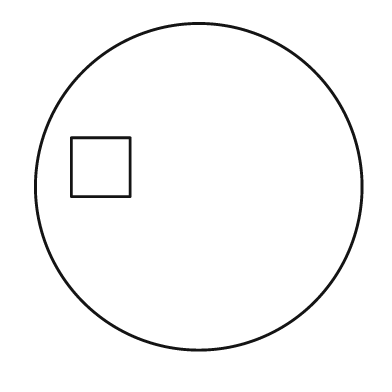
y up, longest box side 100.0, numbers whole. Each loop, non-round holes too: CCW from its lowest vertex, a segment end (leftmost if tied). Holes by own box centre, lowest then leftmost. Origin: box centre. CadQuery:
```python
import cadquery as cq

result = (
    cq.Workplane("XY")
    .moveTo(0.0, 0.0)
    .circle(50.0)
    .moveTo(-39.0, -3.0)
    .lineTo(-21.0, -3.0)
    .lineTo(-21.0, 15.0)
    .lineTo(-39.0, 15.0)
    .close()
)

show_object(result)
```